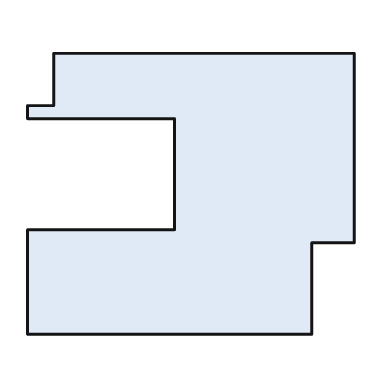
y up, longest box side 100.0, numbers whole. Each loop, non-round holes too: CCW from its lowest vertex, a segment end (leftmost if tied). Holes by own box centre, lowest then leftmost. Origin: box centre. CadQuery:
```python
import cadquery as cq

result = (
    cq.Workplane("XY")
    .moveTo(-50.0, -43.0)
    .lineTo(37.0, -43.0)
    .lineTo(37.0, -15.0)
    .lineTo(50.0, -15.0)
    .lineTo(50.0, 43.0)
    .lineTo(-42.0, 43.0)
    .lineTo(-42.0, 27.0)
    .lineTo(-50.0, 27.0)
    .lineTo(-50.0, 23.0)
    .lineTo(-5.0, 23.0)
    .lineTo(-5.0, -11.0)
    .lineTo(-50.0, -11.0)
    .close()
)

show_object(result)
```